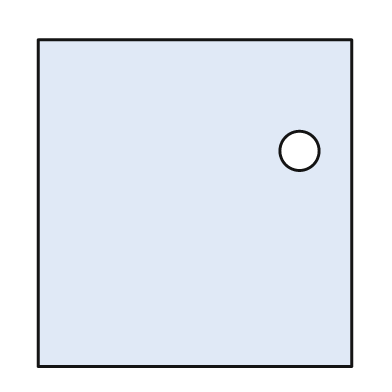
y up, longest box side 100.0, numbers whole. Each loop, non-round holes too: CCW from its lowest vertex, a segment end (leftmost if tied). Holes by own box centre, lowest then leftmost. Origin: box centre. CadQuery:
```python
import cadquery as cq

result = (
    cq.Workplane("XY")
    .moveTo(-48.0, -50.0)
    .lineTo(48.0, -50.0)
    .lineTo(48.0, 50.0)
    .lineTo(-48.0, 50.0)
    .close()
    .moveTo(32.0, 16.0)
    .circle(6.0)
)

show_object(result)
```